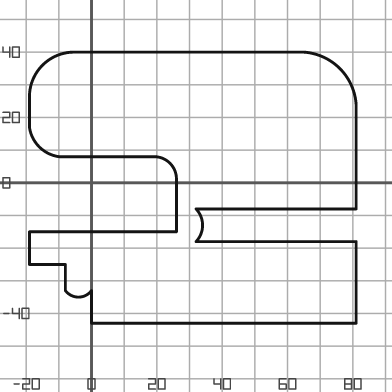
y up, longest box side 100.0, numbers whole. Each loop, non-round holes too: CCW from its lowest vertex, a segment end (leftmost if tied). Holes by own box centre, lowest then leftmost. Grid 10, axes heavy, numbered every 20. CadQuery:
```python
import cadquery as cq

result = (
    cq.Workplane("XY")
    .moveTo(0.0, -43.0)
    .lineTo(81.0, -43.0)
    .lineTo(81.0, -18.0)
    .lineTo(32.0, -18.0)
    .threePointArc((34.0, -13.0), (32.0, -8.0))
    .lineTo(81.0, -8.0)
    .lineTo(81.0, 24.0)
    .threePointArc((76.0, 35.0), (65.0, 40.0))
    .lineTo(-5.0, 40.0)
    .threePointArc((-15.0, 36.0), (-19.0, 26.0))
    .lineTo(-19.0, 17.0)
    .threePointArc((-16.0, 11.0), (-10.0, 8.0))
    .lineTo(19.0, 8.0)
    .threePointArc((24.0, 6.0), (26.0, 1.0))
    .lineTo(26.0, -15.0)
    .lineTo(-19.0, -15.0)
    .lineTo(-19.0, -25.0)
    .lineTo(-8.0, -25.0)
    .lineTo(-8.0, -33.0)
    .threePointArc((-4.0, -35.0), (0.0, -33.0))
    .close()
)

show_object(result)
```